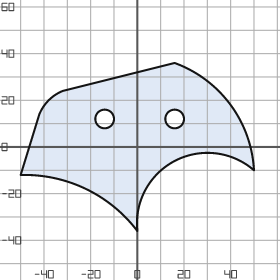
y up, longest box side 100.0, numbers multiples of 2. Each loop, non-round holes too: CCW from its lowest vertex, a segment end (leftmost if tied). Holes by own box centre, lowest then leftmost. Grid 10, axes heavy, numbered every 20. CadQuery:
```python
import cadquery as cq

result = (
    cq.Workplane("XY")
    .moveTo(0.0, -36.0)
    .threePointArc((16.0, -6.0), (50.0, -10.0))
    .threePointArc((40.0, 18.0), (16.0, 36.0))
    .lineTo(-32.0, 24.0)
    .threePointArc((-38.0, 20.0), (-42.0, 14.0))
    .lineTo(-50.0, -12.0)
    .threePointArc((-22.0, -18.0), (0.0, -36.0))
    .close()
    .moveTo(-14.0, 12.0)
    .circle(4.0)
    .moveTo(16.0, 12.0)
    .circle(4.0)
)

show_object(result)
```